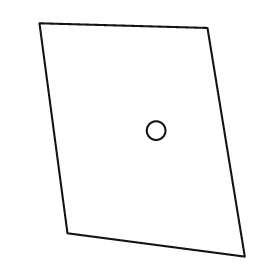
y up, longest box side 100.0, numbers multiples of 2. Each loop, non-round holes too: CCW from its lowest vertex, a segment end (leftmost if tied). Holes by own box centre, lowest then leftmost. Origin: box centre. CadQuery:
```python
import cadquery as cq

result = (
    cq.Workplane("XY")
    .moveTo(44.0, -50.0)
    .lineTo(28.0, 48.0)
    .lineTo(-44.0, 50.0)
    .lineTo(-32.0, -40.0)
    .close()
    .moveTo(6.0, 4.0)
    .circle(4.0)
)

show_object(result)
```